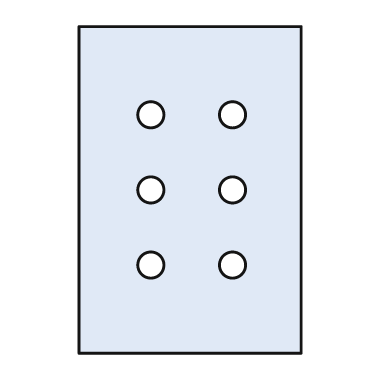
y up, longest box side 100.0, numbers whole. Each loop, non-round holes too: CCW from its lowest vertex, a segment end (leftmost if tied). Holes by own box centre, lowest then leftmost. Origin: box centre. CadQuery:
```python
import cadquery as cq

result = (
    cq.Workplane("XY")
    .moveTo(-34.0, -50.0)
    .lineTo(34.0, -50.0)
    .lineTo(34.0, 50.0)
    .lineTo(-34.0, 50.0)
    .close()
    .moveTo(-12.0, -23.0)
    .circle(4.0)
    .moveTo(13.0, -23.0)
    .circle(4.0)
    .moveTo(-12.0, 0.0)
    .circle(4.0)
    .moveTo(13.0, 0.0)
    .circle(4.0)
    .moveTo(-12.0, 23.0)
    .circle(4.0)
    .moveTo(13.0, 23.0)
    .circle(4.0)
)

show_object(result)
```